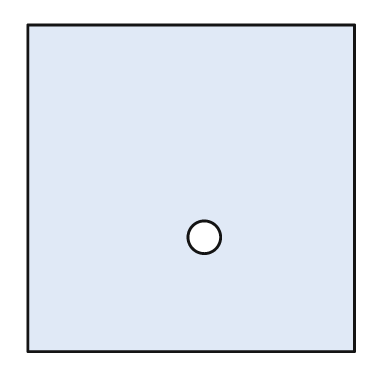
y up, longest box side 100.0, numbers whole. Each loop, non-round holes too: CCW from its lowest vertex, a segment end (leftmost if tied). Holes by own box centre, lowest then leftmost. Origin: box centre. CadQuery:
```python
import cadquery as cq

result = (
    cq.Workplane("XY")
    .moveTo(-50.0, -50.0)
    .lineTo(50.0, -50.0)
    .lineTo(50.0, 50.0)
    .lineTo(-50.0, 50.0)
    .close()
    .moveTo(4.0, -15.0)
    .circle(5.0)
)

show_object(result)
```